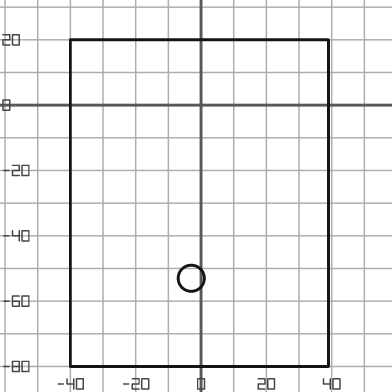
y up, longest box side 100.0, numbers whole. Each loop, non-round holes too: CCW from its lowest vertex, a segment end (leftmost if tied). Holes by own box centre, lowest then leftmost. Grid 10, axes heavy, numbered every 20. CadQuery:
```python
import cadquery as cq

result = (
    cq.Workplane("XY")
    .moveTo(-40.0, -80.0)
    .lineTo(39.0, -80.0)
    .lineTo(39.0, 20.0)
    .lineTo(-40.0, 20.0)
    .close()
    .moveTo(-3.0, -53.0)
    .circle(4.0)
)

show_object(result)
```